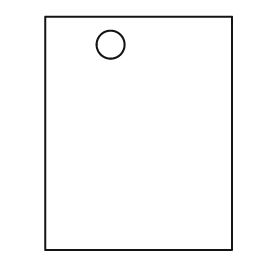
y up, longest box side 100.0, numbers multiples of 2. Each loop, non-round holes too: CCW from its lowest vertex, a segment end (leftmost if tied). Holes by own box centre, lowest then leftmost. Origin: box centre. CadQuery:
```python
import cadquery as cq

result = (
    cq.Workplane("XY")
    .moveTo(-40.0, -50.0)
    .lineTo(40.0, -50.0)
    .lineTo(40.0, 50.0)
    .lineTo(-40.0, 50.0)
    .close()
    .moveTo(-12.0, 38.0)
    .circle(6.0)
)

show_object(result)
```